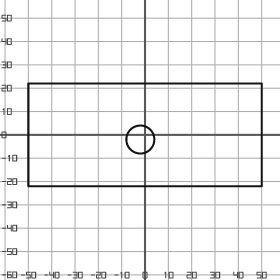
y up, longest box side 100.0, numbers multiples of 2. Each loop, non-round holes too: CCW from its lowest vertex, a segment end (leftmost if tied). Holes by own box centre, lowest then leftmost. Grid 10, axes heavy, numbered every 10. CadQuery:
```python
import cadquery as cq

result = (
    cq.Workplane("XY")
    .moveTo(-50.0, -22.0)
    .lineTo(50.0, -22.0)
    .lineTo(50.0, 22.0)
    .lineTo(-50.0, 22.0)
    .close()
    .moveTo(-2.0, -2.0)
    .circle(6.0)
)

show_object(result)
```